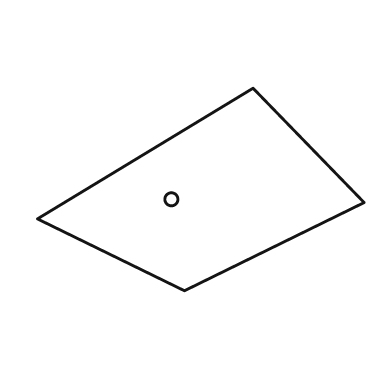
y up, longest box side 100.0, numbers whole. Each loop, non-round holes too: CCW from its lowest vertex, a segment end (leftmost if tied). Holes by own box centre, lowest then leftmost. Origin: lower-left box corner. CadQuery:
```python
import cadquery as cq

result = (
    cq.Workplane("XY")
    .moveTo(45.0, 0.0)
    .lineTo(100.0, 27.0)
    .lineTo(66.0, 62.0)
    .lineTo(0.0, 22.0)
    .close()
    .moveTo(41.0, 28.0)
    .circle(2.0)
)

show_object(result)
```